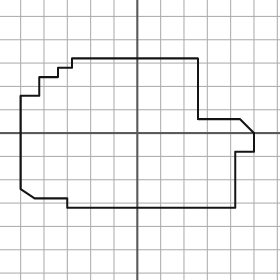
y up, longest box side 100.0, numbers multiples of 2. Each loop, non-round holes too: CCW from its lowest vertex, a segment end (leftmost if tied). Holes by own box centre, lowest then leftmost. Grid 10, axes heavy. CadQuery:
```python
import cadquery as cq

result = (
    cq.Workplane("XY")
    .moveTo(-30.0, -32.0)
    .lineTo(42.0, -32.0)
    .lineTo(42.0, -8.0)
    .lineTo(50.0, -8.0)
    .lineTo(50.0, 0.0)
    .lineTo(44.0, 6.0)
    .lineTo(26.0, 6.0)
    .lineTo(26.0, 32.0)
    .lineTo(-28.0, 32.0)
    .lineTo(-28.0, 28.0)
    .lineTo(-34.0, 28.0)
    .lineTo(-34.0, 24.0)
    .lineTo(-42.0, 24.0)
    .lineTo(-42.0, 16.0)
    .lineTo(-50.0, 16.0)
    .lineTo(-50.0, -24.0)
    .lineTo(-44.0, -28.0)
    .lineTo(-30.0, -28.0)
    .close()
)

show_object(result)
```